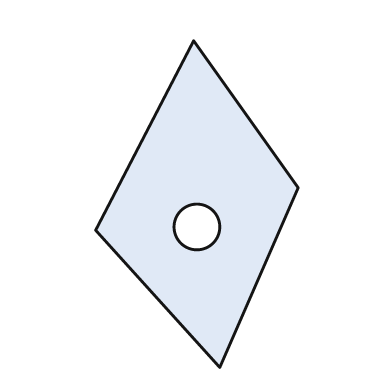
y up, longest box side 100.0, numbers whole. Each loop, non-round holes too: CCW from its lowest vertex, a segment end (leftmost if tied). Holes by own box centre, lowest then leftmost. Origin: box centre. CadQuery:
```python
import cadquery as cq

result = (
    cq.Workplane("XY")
    .moveTo(7.0, -50.0)
    .lineTo(31.0, 5.0)
    .lineTo(-1.0, 50.0)
    .lineTo(-31.0, -8.0)
    .close()
    .moveTo(0.0, -7.0)
    .circle(7.0)
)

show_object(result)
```